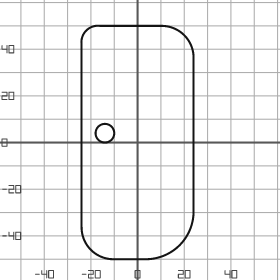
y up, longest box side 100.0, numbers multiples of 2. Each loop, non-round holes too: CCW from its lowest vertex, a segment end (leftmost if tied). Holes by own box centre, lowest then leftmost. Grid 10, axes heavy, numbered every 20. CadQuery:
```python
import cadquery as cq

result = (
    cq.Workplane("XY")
    .moveTo(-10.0, -50.0)
    .lineTo(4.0, -50.0)
    .threePointArc((18.0, -44.0), (24.0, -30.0))
    .lineTo(24.0, 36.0)
    .threePointArc((20.0, 46.0), (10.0, 50.0))
    .lineTo(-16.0, 50.0)
    .threePointArc((-22.0, 48.0), (-24.0, 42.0))
    .lineTo(-24.0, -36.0)
    .threePointArc((-20.0, -46.0), (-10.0, -50.0))
    .close()
    .moveTo(-14.0, 4.0)
    .circle(4.0)
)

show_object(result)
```